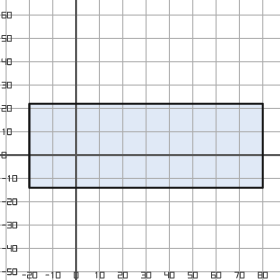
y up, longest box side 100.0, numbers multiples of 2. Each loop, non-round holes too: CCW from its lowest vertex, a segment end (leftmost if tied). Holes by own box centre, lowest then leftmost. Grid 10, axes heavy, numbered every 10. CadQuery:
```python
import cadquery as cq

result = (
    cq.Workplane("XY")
    .moveTo(-20.0, -14.0)
    .lineTo(80.0, -14.0)
    .lineTo(80.0, 22.0)
    .lineTo(-20.0, 22.0)
    .close()
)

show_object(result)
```